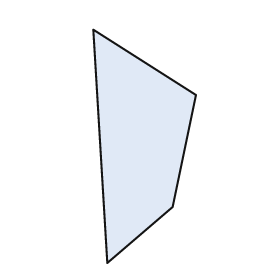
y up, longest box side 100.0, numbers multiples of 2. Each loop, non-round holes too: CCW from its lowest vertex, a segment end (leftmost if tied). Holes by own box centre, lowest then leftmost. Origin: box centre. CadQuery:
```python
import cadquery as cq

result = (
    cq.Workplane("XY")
    .moveTo(-16.0, -50.0)
    .lineTo(12.0, -26.0)
    .lineTo(22.0, 22.0)
    .lineTo(-22.0, 50.0)
    .close()
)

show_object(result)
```